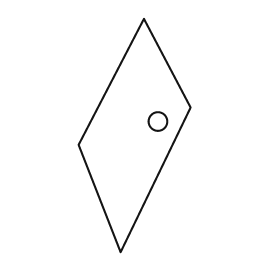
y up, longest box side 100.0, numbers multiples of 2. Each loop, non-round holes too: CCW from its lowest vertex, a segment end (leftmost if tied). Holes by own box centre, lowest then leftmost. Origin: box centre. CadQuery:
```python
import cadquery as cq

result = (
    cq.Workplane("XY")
    .moveTo(-6.0, -50.0)
    .lineTo(24.0, 12.0)
    .lineTo(4.0, 50.0)
    .lineTo(-24.0, -4.0)
    .close()
    .moveTo(10.0, 6.0)
    .circle(4.0)
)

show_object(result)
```